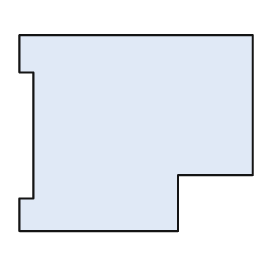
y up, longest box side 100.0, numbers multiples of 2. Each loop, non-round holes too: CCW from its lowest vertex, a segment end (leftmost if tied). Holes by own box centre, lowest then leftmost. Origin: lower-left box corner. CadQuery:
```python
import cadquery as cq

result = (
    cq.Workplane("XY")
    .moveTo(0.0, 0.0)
    .lineTo(68.0, 0.0)
    .lineTo(68.0, 24.0)
    .lineTo(100.0, 24.0)
    .lineTo(100.0, 84.0)
    .lineTo(0.0, 84.0)
    .lineTo(0.0, 68.0)
    .lineTo(6.0, 68.0)
    .lineTo(6.0, 14.0)
    .lineTo(0.0, 14.0)
    .close()
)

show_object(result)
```